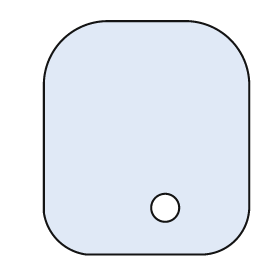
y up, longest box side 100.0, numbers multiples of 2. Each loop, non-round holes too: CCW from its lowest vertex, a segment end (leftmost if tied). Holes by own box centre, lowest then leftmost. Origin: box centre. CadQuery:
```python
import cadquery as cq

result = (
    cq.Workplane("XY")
    .moveTo(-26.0, -50.0)
    .lineTo(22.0, -50.0)
    .threePointArc((38.0, -44.0), (44.0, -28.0))
    .lineTo(44.0, 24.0)
    .threePointArc((36.0, 42.0), (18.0, 50.0))
    .lineTo(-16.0, 50.0)
    .threePointArc((-36.0, 42.0), (-44.0, 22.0))
    .lineTo(-44.0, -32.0)
    .threePointArc((-38.0, -44.0), (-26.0, -50.0))
    .close()
    .moveTo(8.0, -30.0)
    .circle(6.0)
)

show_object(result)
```